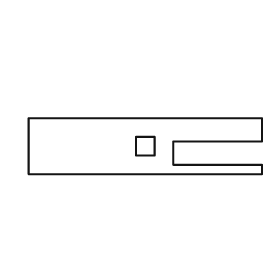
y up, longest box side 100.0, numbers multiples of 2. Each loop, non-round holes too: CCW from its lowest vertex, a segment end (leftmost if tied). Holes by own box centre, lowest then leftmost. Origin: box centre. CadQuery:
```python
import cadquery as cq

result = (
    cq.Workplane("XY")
    .moveTo(-50.0, -12.0)
    .lineTo(50.0, -12.0)
    .lineTo(50.0, -8.0)
    .lineTo(12.0, -8.0)
    .lineTo(12.0, 2.0)
    .lineTo(50.0, 2.0)
    .lineTo(50.0, 12.0)
    .lineTo(-50.0, 12.0)
    .close()
    .moveTo(-4.0, -4.0)
    .lineTo(4.0, -4.0)
    .lineTo(4.0, 4.0)
    .lineTo(-4.0, 4.0)
    .close()
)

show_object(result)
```